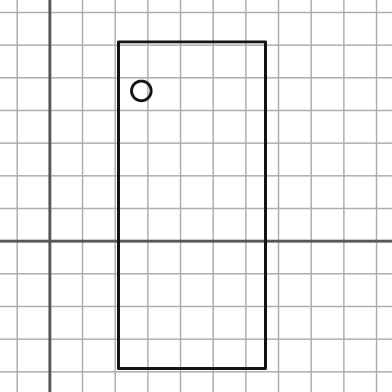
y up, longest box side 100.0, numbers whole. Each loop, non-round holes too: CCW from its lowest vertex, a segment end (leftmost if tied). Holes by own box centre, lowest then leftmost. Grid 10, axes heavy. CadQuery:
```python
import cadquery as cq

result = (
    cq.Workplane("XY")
    .moveTo(21.0, -39.0)
    .lineTo(66.0, -39.0)
    .lineTo(66.0, 61.0)
    .lineTo(21.0, 61.0)
    .close()
    .moveTo(28.0, 46.0)
    .circle(3.0)
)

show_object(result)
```